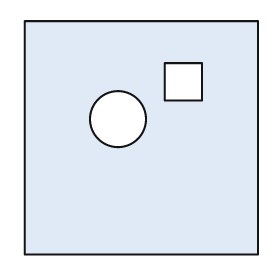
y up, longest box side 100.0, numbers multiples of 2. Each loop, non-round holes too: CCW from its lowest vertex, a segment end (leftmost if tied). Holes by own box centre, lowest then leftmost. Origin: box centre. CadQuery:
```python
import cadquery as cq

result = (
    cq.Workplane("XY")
    .moveTo(-50.0, -50.0)
    .lineTo(50.0, -50.0)
    .lineTo(50.0, 50.0)
    .lineTo(-50.0, 50.0)
    .close()
    .moveTo(-10.0, 8.0)
    .circle(12.0)
    .moveTo(10.0, 16.0)
    .lineTo(26.0, 16.0)
    .lineTo(26.0, 32.0)
    .lineTo(10.0, 32.0)
    .close()
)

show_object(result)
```